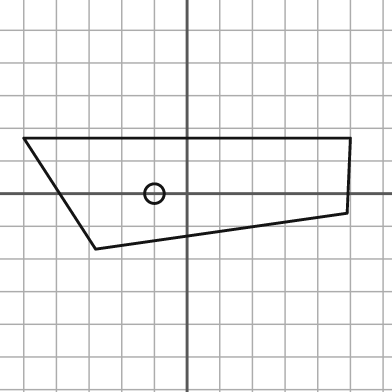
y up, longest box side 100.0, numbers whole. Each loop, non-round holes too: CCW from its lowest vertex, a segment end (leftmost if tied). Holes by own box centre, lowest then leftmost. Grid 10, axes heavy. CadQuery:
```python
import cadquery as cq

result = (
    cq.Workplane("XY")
    .moveTo(-28.0, -17.0)
    .lineTo(49.0, -6.0)
    .lineTo(50.0, 17.0)
    .lineTo(-50.0, 17.0)
    .close()
    .moveTo(-10.0, 0.0)
    .circle(3.0)
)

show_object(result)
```